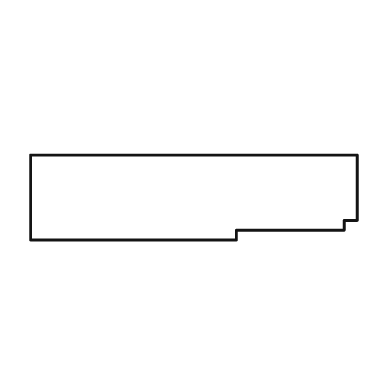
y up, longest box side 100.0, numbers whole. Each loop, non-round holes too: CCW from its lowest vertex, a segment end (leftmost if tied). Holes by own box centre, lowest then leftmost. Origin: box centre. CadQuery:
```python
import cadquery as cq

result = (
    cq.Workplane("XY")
    .moveTo(-50.0, -13.0)
    .lineTo(13.0, -13.0)
    .lineTo(13.0, -10.0)
    .lineTo(46.0, -10.0)
    .lineTo(46.0, -7.0)
    .lineTo(50.0, -7.0)
    .lineTo(50.0, 13.0)
    .lineTo(-50.0, 13.0)
    .close()
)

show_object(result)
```